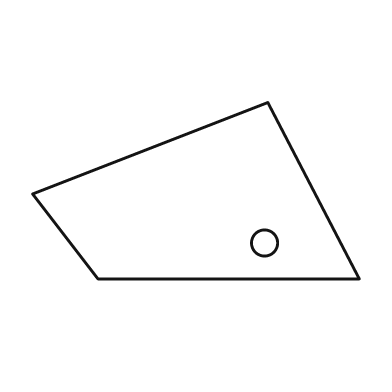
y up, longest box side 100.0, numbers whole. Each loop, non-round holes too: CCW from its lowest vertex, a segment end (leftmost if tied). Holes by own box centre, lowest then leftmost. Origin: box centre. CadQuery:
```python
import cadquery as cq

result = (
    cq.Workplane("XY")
    .moveTo(-30.0, -27.0)
    .lineTo(50.0, -27.0)
    .lineTo(22.0, 27.0)
    .lineTo(-50.0, -1.0)
    .close()
    .moveTo(21.0, -16.0)
    .circle(4.0)
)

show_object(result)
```